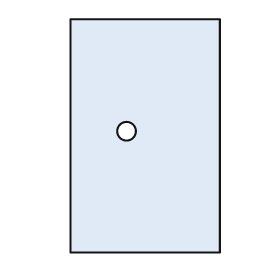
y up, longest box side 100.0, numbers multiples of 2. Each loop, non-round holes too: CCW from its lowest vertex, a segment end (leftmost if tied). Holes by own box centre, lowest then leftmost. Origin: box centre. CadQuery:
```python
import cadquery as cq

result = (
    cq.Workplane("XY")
    .moveTo(-32.0, -50.0)
    .lineTo(32.0, -50.0)
    .lineTo(32.0, 50.0)
    .lineTo(-32.0, 50.0)
    .close()
    .moveTo(-8.0, 2.0)
    .circle(4.0)
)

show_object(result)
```